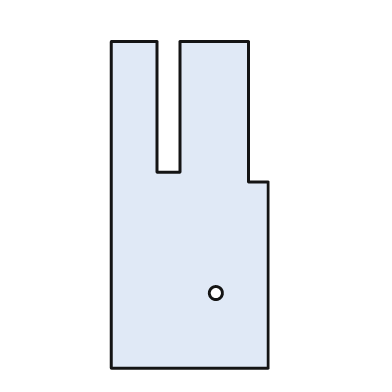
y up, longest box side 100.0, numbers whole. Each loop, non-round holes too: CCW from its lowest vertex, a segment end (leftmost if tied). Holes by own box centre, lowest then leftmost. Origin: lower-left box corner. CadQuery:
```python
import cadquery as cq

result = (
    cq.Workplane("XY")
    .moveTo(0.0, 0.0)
    .lineTo(48.0, 0.0)
    .lineTo(48.0, 57.0)
    .lineTo(42.0, 57.0)
    .lineTo(42.0, 100.0)
    .lineTo(21.0, 100.0)
    .lineTo(21.0, 60.0)
    .lineTo(14.0, 60.0)
    .lineTo(14.0, 100.0)
    .lineTo(0.0, 100.0)
    .close()
    .moveTo(32.0, 23.0)
    .circle(2.0)
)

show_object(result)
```